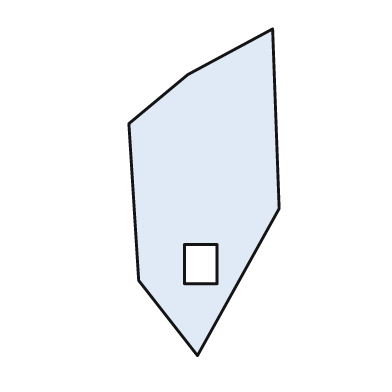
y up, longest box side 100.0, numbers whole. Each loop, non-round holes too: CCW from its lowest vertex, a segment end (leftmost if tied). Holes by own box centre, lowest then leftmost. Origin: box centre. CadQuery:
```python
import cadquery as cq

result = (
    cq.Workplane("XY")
    .moveTo(-2.0, -50.0)
    .lineTo(23.0, -5.0)
    .lineTo(21.0, 50.0)
    .lineTo(-5.0, 36.0)
    .lineTo(-23.0, 21.0)
    .lineTo(-20.0, -27.0)
    .close()
    .moveTo(-6.0, -28.0)
    .lineTo(4.0, -28.0)
    .lineTo(4.0, -16.0)
    .lineTo(-6.0, -16.0)
    .close()
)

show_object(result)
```